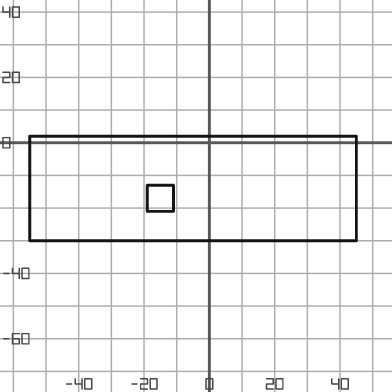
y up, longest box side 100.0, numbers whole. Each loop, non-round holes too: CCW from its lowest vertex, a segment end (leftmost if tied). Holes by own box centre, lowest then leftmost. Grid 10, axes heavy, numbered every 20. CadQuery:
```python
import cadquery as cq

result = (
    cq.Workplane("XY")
    .moveTo(-55.0, -30.0)
    .lineTo(45.0, -30.0)
    .lineTo(45.0, 2.0)
    .lineTo(-55.0, 2.0)
    .close()
    .moveTo(-19.0, -21.0)
    .lineTo(-11.0, -21.0)
    .lineTo(-11.0, -13.0)
    .lineTo(-19.0, -13.0)
    .close()
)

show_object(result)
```